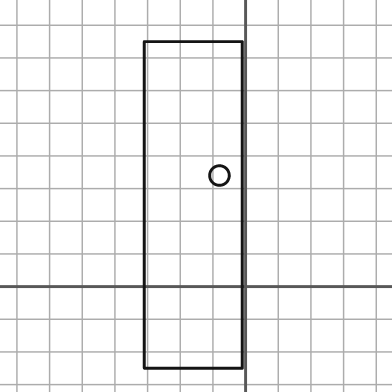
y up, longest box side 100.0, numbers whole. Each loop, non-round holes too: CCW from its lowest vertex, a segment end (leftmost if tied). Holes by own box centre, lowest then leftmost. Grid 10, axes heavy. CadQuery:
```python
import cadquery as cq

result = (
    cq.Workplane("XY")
    .moveTo(-31.0, -25.0)
    .lineTo(-1.0, -25.0)
    .lineTo(-1.0, 75.0)
    .lineTo(-31.0, 75.0)
    .close()
    .moveTo(-8.0, 34.0)
    .circle(3.0)
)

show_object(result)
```